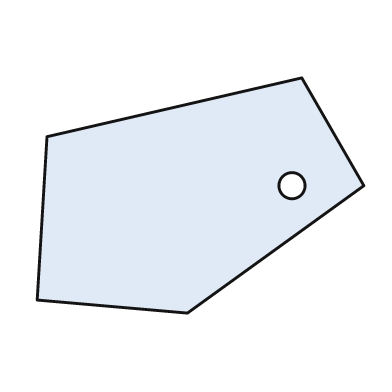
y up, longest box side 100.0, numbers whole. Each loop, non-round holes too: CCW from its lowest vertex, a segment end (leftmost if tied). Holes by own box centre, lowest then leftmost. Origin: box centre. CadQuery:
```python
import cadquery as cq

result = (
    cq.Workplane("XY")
    .moveTo(-4.0, -36.0)
    .lineTo(50.0, 3.0)
    .lineTo(31.0, 36.0)
    .lineTo(-47.0, 18.0)
    .lineTo(-50.0, -32.0)
    .close()
    .moveTo(28.0, 3.0)
    .circle(4.0)
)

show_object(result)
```